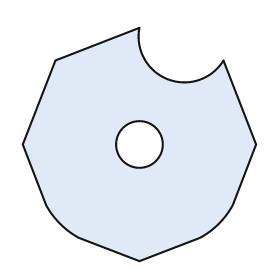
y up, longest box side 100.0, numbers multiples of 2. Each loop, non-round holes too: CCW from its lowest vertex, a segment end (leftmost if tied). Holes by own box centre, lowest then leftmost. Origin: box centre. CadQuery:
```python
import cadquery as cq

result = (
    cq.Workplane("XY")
    .moveTo(0.0, -50.0)
    .lineTo(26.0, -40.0)
    .threePointArc((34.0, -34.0), (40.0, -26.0))
    .lineTo(50.0, 0.0)
    .lineTo(36.0, 36.0)
    .threePointArc((12.0, 28.0), (0.0, 50.0))
    .lineTo(-36.0, 36.0)
    .lineTo(-50.0, 0.0)
    .lineTo(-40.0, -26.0)
    .threePointArc((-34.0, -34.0), (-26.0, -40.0))
    .close()
    .moveTo(0.0, 0.0)
    .circle(10.0)
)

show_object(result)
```